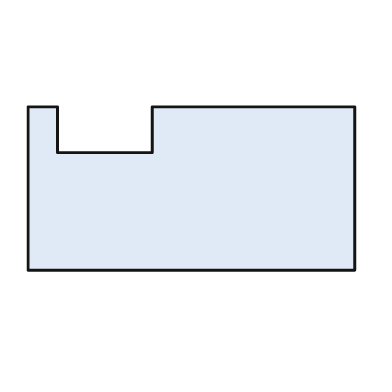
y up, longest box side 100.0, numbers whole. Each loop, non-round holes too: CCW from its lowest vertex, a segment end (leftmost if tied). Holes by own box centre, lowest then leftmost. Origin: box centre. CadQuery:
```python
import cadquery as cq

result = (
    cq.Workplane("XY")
    .moveTo(-50.0, -25.0)
    .lineTo(50.0, -25.0)
    .lineTo(50.0, 25.0)
    .lineTo(-12.0, 25.0)
    .lineTo(-12.0, 11.0)
    .lineTo(-41.0, 11.0)
    .lineTo(-41.0, 25.0)
    .lineTo(-50.0, 25.0)
    .close()
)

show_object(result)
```